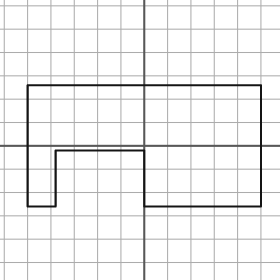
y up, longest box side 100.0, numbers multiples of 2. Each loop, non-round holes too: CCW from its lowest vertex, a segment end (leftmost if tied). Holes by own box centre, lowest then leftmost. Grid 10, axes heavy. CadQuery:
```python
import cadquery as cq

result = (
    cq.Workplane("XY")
    .moveTo(-50.0, -26.0)
    .lineTo(-38.0, -26.0)
    .lineTo(-38.0, -2.0)
    .lineTo(0.0, -2.0)
    .lineTo(0.0, -26.0)
    .lineTo(50.0, -26.0)
    .lineTo(50.0, 26.0)
    .lineTo(-50.0, 26.0)
    .close()
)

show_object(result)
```